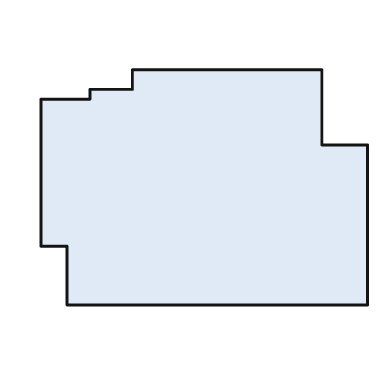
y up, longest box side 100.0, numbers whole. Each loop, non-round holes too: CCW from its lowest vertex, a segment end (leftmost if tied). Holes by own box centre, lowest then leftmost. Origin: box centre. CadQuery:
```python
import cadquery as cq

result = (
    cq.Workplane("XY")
    .moveTo(-42.0, -36.0)
    .lineTo(50.0, -36.0)
    .lineTo(50.0, 13.0)
    .lineTo(36.0, 13.0)
    .lineTo(36.0, 36.0)
    .lineTo(-22.0, 36.0)
    .lineTo(-22.0, 30.0)
    .lineTo(-35.0, 30.0)
    .lineTo(-35.0, 27.0)
    .lineTo(-50.0, 27.0)
    .lineTo(-50.0, -18.0)
    .lineTo(-42.0, -18.0)
    .close()
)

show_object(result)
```